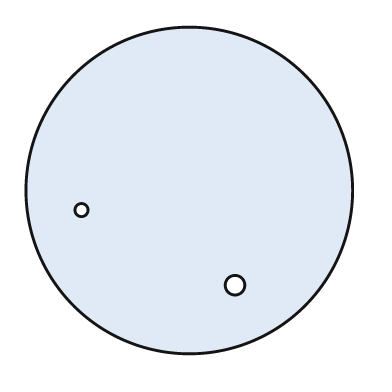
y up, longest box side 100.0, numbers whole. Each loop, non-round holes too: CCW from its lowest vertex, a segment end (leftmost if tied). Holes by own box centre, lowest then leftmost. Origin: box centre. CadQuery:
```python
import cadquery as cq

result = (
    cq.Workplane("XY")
    .moveTo(0.0, 0.0)
    .circle(50.0)
    .moveTo(14.0, -29.0)
    .circle(3.0)
    .moveTo(-33.0, -6.0)
    .circle(2.0)
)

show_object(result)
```